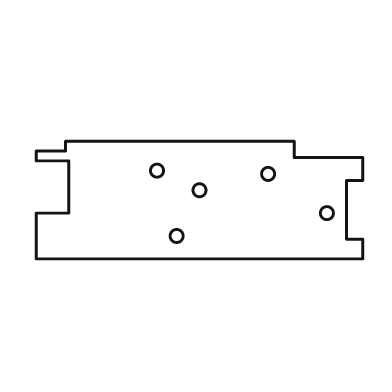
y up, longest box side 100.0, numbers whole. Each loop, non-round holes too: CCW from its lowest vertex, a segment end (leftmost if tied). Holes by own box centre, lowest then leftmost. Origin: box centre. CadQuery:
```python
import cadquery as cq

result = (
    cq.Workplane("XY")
    .moveTo(-50.0, -18.0)
    .lineTo(50.0, -18.0)
    .lineTo(50.0, -12.0)
    .lineTo(45.0, -12.0)
    .lineTo(45.0, 6.0)
    .lineTo(50.0, 6.0)
    .lineTo(50.0, 13.0)
    .lineTo(29.0, 13.0)
    .lineTo(29.0, 18.0)
    .lineTo(-41.0, 18.0)
    .lineTo(-41.0, 15.0)
    .lineTo(-50.0, 15.0)
    .lineTo(-50.0, 12.0)
    .lineTo(-40.0, 12.0)
    .lineTo(-40.0, -4.0)
    .lineTo(-50.0, -4.0)
    .close()
    .moveTo(-7.0, -11.0)
    .circle(2.0)
    .moveTo(39.0, -4.0)
    .circle(2.0)
    .moveTo(0.0, 3.0)
    .circle(2.0)
    .moveTo(21.0, 8.0)
    .circle(2.0)
    .moveTo(-13.0, 9.0)
    .circle(2.0)
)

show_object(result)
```